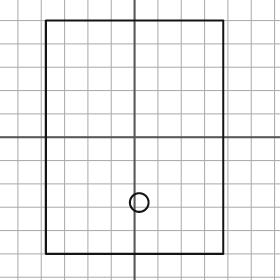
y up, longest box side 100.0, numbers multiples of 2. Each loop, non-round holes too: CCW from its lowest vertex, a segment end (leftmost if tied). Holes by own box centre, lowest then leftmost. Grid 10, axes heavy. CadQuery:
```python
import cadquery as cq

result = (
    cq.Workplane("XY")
    .moveTo(-38.0, -50.0)
    .lineTo(38.0, -50.0)
    .lineTo(38.0, 50.0)
    .lineTo(-38.0, 50.0)
    .close()
    .moveTo(2.0, -28.0)
    .circle(4.0)
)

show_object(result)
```